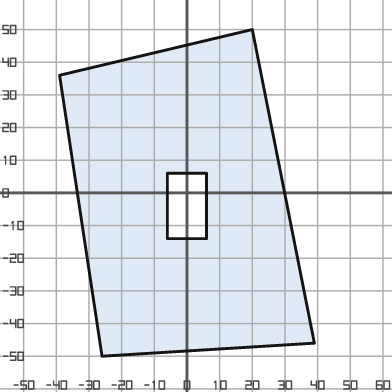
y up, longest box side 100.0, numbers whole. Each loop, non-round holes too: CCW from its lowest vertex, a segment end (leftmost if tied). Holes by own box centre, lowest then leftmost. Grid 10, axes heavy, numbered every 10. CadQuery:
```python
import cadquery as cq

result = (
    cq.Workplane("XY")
    .moveTo(-26.0, -50.0)
    .lineTo(39.0, -46.0)
    .lineTo(20.0, 50.0)
    .lineTo(-39.0, 36.0)
    .close()
    .moveTo(-6.0, -14.0)
    .lineTo(6.0, -14.0)
    .lineTo(6.0, 6.0)
    .lineTo(-6.0, 6.0)
    .close()
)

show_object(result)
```